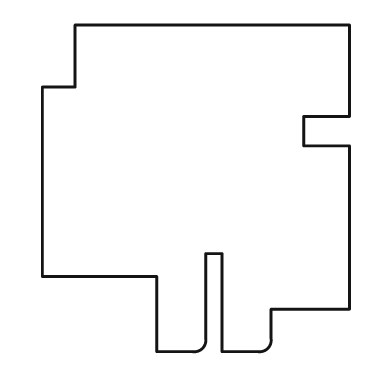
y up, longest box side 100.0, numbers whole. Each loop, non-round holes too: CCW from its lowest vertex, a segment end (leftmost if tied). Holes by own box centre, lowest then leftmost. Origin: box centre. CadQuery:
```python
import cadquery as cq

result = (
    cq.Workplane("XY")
    .moveTo(-12.0, -50.0)
    .lineTo(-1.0, -50.0)
    .threePointArc((2.0, -49.0), (3.0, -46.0))
    .lineTo(3.0, -20.0)
    .lineTo(8.0, -20.0)
    .lineTo(8.0, -50.0)
    .lineTo(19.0, -50.0)
    .threePointArc((22.0, -49.0), (23.0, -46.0))
    .lineTo(23.0, -37.0)
    .lineTo(47.0, -37.0)
    .lineTo(47.0, 13.0)
    .lineTo(33.0, 13.0)
    .lineTo(33.0, 22.0)
    .lineTo(47.0, 22.0)
    .lineTo(47.0, 50.0)
    .lineTo(-37.0, 50.0)
    .lineTo(-37.0, 31.0)
    .lineTo(-47.0, 31.0)
    .lineTo(-47.0, -27.0)
    .lineTo(-12.0, -27.0)
    .close()
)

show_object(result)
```